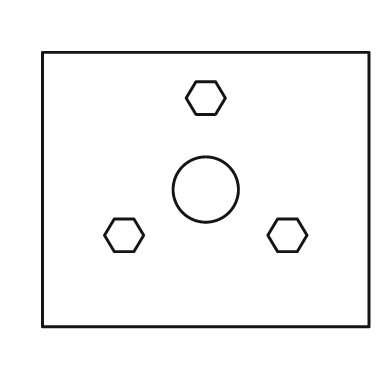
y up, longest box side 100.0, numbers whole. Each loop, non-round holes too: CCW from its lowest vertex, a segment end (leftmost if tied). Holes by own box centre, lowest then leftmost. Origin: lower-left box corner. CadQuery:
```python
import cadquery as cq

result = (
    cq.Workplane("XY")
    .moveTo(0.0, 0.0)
    .lineTo(100.0, 0.0)
    .lineTo(100.0, 84.0)
    .lineTo(0.0, 84.0)
    .close()
    .moveTo(22.0, 23.0)
    .lineTo(28.0, 23.0)
    .lineTo(31.0, 28.0)
    .lineTo(28.0, 33.0)
    .lineTo(22.0, 33.0)
    .lineTo(19.0, 28.0)
    .close()
    .moveTo(72.0, 23.0)
    .lineTo(78.0, 23.0)
    .lineTo(81.0, 28.0)
    .lineTo(78.0, 33.0)
    .lineTo(72.0, 33.0)
    .lineTo(69.0, 28.0)
    .close()
    .moveTo(50.0, 42.0)
    .circle(10.0)
    .moveTo(47.0, 65.0)
    .lineTo(53.0, 65.0)
    .lineTo(56.0, 70.0)
    .lineTo(53.0, 75.0)
    .lineTo(47.0, 75.0)
    .lineTo(44.0, 70.0)
    .close()
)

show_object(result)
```